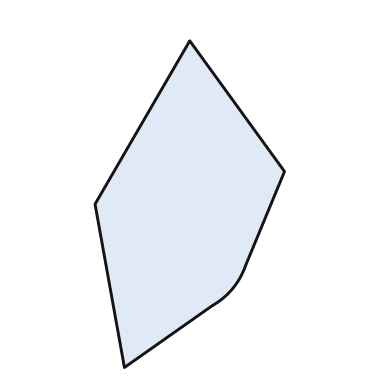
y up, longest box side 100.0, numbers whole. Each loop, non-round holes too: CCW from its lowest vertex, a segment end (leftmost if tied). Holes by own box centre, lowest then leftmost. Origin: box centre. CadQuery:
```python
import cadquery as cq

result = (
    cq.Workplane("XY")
    .moveTo(-20.0, -50.0)
    .lineTo(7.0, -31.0)
    .threePointArc((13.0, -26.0), (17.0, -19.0))
    .lineTo(29.0, 10.0)
    .lineTo(0.0, 50.0)
    .lineTo(-29.0, 0.0)
    .close()
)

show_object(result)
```